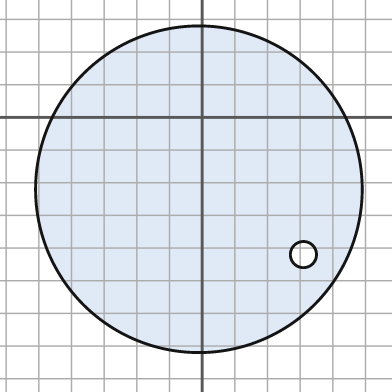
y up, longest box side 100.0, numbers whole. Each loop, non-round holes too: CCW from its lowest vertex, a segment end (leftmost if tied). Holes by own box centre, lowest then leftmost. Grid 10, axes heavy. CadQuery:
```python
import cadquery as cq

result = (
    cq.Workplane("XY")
    .moveTo(-1.0, -22.0)
    .circle(50.0)
    .moveTo(31.0, -42.0)
    .circle(4.0)
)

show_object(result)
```